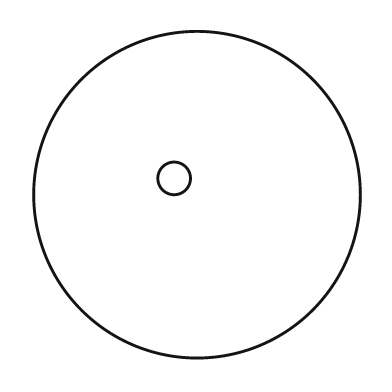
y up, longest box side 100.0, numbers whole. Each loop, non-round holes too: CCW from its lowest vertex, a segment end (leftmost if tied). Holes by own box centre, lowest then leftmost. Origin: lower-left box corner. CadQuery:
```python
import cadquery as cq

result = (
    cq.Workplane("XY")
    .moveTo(50.0, 50.0)
    .circle(50.0)
    .moveTo(43.0, 55.0)
    .circle(5.0)
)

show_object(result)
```